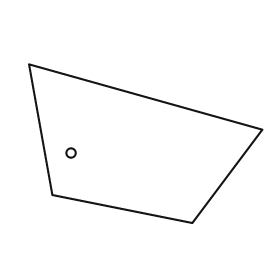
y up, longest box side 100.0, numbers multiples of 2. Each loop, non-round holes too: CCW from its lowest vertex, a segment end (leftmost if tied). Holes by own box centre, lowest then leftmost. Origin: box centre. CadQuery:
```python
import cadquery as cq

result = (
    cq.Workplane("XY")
    .moveTo(20.0, -34.0)
    .lineTo(50.0, 6.0)
    .lineTo(-50.0, 34.0)
    .lineTo(-40.0, -22.0)
    .close()
    .moveTo(-32.0, -4.0)
    .circle(2.0)
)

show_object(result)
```